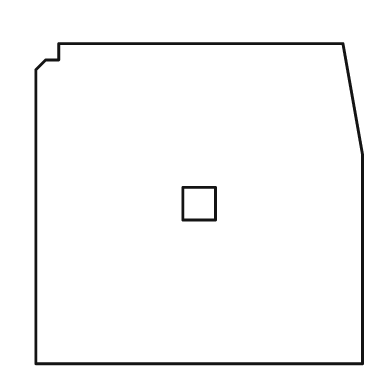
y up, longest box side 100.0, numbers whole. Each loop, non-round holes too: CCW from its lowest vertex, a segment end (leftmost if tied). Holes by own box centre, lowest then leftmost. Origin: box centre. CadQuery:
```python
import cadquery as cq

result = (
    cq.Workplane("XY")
    .moveTo(-50.0, -49.0)
    .lineTo(50.0, -49.0)
    .lineTo(50.0, 15.0)
    .lineTo(44.0, 49.0)
    .lineTo(-43.0, 49.0)
    .lineTo(-43.0, 44.0)
    .lineTo(-47.0, 44.0)
    .lineTo(-50.0, 41.0)
    .close()
    .moveTo(-5.0, -5.0)
    .lineTo(5.0, -5.0)
    .lineTo(5.0, 5.0)
    .lineTo(-5.0, 5.0)
    .close()
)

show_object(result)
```